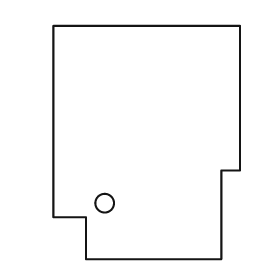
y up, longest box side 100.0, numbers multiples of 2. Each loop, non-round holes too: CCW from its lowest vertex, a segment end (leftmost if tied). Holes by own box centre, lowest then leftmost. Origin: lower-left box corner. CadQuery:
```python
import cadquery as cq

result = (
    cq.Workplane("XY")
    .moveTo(14.0, 0.0)
    .lineTo(72.0, 0.0)
    .lineTo(72.0, 38.0)
    .lineTo(80.0, 38.0)
    .lineTo(80.0, 100.0)
    .lineTo(0.0, 100.0)
    .lineTo(0.0, 18.0)
    .lineTo(14.0, 18.0)
    .close()
    .moveTo(22.0, 24.0)
    .circle(4.0)
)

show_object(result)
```